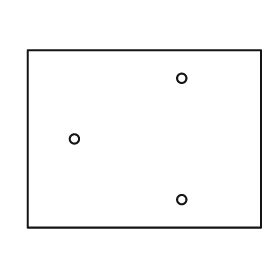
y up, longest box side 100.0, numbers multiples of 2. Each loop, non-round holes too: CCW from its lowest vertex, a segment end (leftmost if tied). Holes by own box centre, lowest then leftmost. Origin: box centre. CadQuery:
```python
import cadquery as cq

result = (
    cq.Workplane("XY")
    .moveTo(-50.0, -38.0)
    .lineTo(50.0, -38.0)
    .lineTo(50.0, 38.0)
    .lineTo(-50.0, 38.0)
    .close()
    .moveTo(16.0, -26.0)
    .circle(2.0)
    .moveTo(-30.0, 0.0)
    .circle(2.0)
    .moveTo(16.0, 26.0)
    .circle(2.0)
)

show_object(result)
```